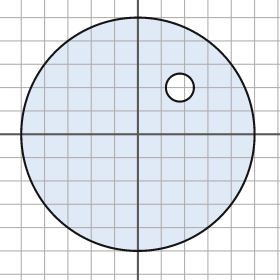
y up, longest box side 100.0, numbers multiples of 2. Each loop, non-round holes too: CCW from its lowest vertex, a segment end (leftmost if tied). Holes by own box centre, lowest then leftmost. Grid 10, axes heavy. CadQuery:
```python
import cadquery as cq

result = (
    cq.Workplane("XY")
    .moveTo(0.0, 0.0)
    .circle(50.0)
    .moveTo(18.0, 20.0)
    .circle(6.0)
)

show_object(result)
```